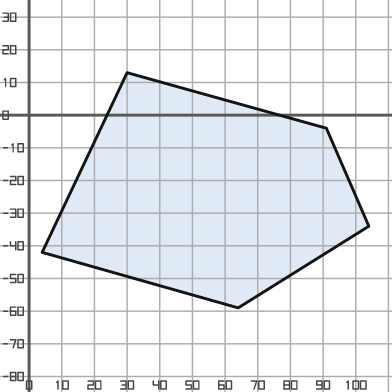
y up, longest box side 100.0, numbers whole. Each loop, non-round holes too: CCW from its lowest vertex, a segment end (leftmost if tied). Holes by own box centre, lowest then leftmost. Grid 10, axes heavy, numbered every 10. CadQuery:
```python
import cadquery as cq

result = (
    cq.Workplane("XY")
    .moveTo(64.0, -59.0)
    .lineTo(104.0, -34.0)
    .lineTo(91.0, -4.0)
    .lineTo(30.0, 13.0)
    .lineTo(4.0, -42.0)
    .close()
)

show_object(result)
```